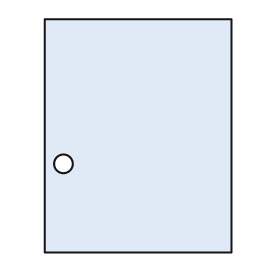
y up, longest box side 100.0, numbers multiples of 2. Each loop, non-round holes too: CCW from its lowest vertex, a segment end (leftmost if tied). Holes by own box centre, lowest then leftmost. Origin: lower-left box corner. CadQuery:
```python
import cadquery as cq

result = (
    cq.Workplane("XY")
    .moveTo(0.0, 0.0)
    .lineTo(80.0, 0.0)
    .lineTo(80.0, 100.0)
    .lineTo(0.0, 100.0)
    .close()
    .moveTo(8.0, 38.0)
    .circle(4.0)
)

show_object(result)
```